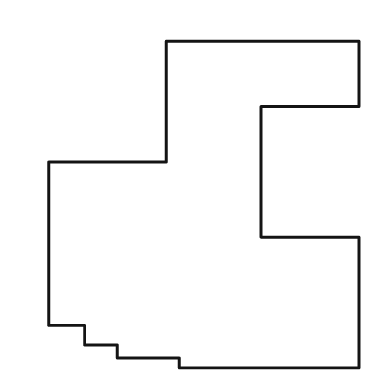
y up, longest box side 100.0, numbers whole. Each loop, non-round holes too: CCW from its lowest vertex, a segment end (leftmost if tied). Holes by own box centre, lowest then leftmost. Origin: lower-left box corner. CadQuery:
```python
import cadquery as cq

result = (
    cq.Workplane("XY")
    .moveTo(40.0, 0.0)
    .lineTo(95.0, 0.0)
    .lineTo(95.0, 40.0)
    .lineTo(65.0, 40.0)
    .lineTo(65.0, 80.0)
    .lineTo(95.0, 80.0)
    .lineTo(95.0, 100.0)
    .lineTo(36.0, 100.0)
    .lineTo(36.0, 63.0)
    .lineTo(0.0, 63.0)
    .lineTo(0.0, 13.0)
    .lineTo(11.0, 13.0)
    .lineTo(11.0, 7.0)
    .lineTo(21.0, 7.0)
    .lineTo(21.0, 3.0)
    .lineTo(40.0, 3.0)
    .close()
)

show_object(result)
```